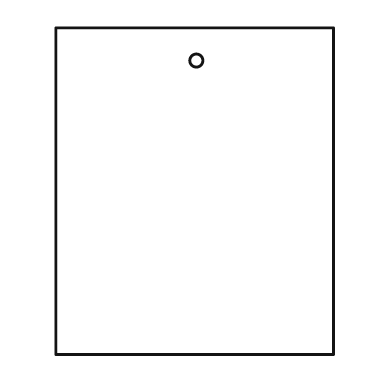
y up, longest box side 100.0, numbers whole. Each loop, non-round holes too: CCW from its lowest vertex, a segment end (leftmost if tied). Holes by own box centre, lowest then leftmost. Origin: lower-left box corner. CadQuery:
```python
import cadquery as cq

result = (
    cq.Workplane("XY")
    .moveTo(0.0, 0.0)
    .lineTo(85.0, 0.0)
    .lineTo(85.0, 100.0)
    .lineTo(0.0, 100.0)
    .close()
    .moveTo(43.0, 90.0)
    .circle(2.0)
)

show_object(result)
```